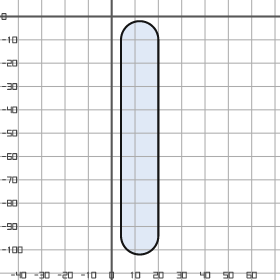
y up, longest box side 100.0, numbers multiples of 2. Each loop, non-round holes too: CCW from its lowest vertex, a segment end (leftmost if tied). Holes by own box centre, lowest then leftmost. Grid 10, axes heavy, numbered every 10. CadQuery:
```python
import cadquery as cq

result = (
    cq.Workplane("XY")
    .moveTo(4.0, -94.0)
    .threePointArc((12.0, -102.0), (20.0, -94.0))
    .lineTo(20.0, -10.0)
    .threePointArc((12.0, -2.0), (4.0, -10.0))
    .close()
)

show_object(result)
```